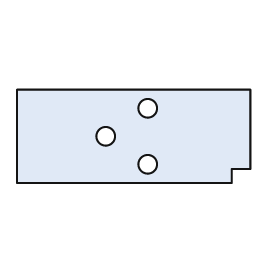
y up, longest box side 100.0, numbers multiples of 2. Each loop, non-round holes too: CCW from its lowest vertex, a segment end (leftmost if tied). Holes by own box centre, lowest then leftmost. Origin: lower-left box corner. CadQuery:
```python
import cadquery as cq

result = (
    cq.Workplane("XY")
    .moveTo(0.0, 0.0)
    .lineTo(92.0, 0.0)
    .lineTo(92.0, 6.0)
    .lineTo(100.0, 6.0)
    .lineTo(100.0, 40.0)
    .lineTo(0.0, 40.0)
    .close()
    .moveTo(56.0, 8.0)
    .circle(4.0)
    .moveTo(38.0, 20.0)
    .circle(4.0)
    .moveTo(56.0, 32.0)
    .circle(4.0)
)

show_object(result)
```